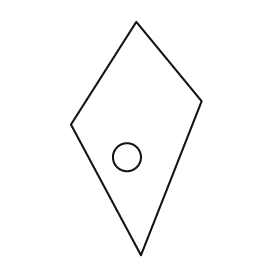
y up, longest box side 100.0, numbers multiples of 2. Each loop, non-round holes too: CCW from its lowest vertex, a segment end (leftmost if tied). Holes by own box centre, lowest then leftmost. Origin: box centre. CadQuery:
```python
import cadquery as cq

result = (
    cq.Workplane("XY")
    .moveTo(2.0, -50.0)
    .lineTo(28.0, 16.0)
    .lineTo(0.0, 50.0)
    .lineTo(-28.0, 6.0)
    .close()
    .moveTo(-4.0, -8.0)
    .circle(6.0)
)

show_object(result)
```